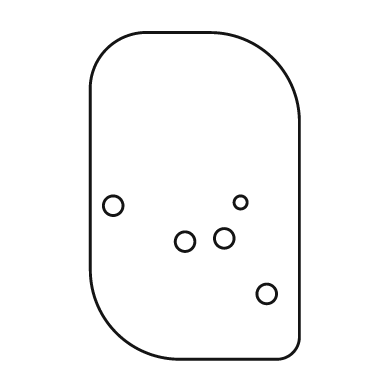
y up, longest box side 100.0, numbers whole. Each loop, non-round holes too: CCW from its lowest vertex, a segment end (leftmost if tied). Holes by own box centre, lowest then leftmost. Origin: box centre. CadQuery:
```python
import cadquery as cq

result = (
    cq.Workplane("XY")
    .moveTo(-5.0, -50.0)
    .lineTo(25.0, -50.0)
    .threePointArc((30.0, -48.0), (32.0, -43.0))
    .lineTo(32.0, 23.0)
    .threePointArc((24.0, 42.0), (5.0, 50.0))
    .lineTo(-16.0, 50.0)
    .threePointArc((-27.0, 45.0), (-32.0, 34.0))
    .lineTo(-32.0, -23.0)
    .threePointArc((-24.0, -42.0), (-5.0, -50.0))
    .close()
    .moveTo(22.0, -30.0)
    .circle(3.0)
    .moveTo(-3.0, -14.0)
    .circle(3.0)
    .moveTo(9.0, -13.0)
    .circle(3.0)
    .moveTo(-25.0, -3.0)
    .circle(3.0)
    .moveTo(14.0, -2.0)
    .circle(2.0)
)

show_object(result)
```